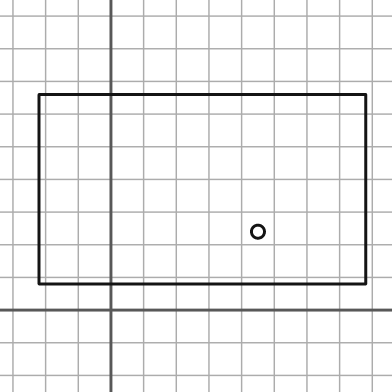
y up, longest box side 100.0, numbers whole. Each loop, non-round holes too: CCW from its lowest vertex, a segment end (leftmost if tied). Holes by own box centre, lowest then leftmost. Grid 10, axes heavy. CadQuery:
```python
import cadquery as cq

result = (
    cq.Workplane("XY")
    .moveTo(-22.0, 8.0)
    .lineTo(78.0, 8.0)
    .lineTo(78.0, 66.0)
    .lineTo(-22.0, 66.0)
    .close()
    .moveTo(45.0, 24.0)
    .circle(2.0)
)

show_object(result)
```